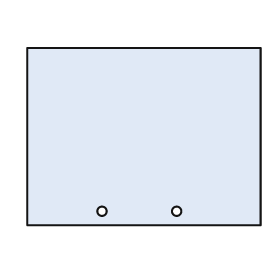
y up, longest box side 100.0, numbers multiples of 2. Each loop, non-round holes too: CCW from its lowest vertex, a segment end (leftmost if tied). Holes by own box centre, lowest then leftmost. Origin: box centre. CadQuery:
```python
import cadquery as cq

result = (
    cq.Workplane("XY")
    .moveTo(-50.0, -38.0)
    .lineTo(50.0, -38.0)
    .lineTo(50.0, 38.0)
    .lineTo(-50.0, 38.0)
    .close()
    .moveTo(-18.0, -32.0)
    .circle(2.0)
    .moveTo(14.0, -32.0)
    .circle(2.0)
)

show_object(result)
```